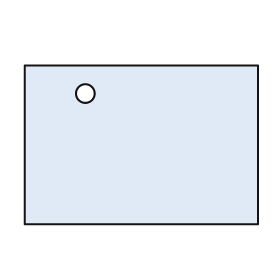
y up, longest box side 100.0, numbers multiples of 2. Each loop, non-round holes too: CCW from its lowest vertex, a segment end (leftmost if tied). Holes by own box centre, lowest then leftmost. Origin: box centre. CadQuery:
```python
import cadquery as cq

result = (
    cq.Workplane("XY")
    .moveTo(-50.0, -34.0)
    .lineTo(50.0, -34.0)
    .lineTo(50.0, 34.0)
    .lineTo(-50.0, 34.0)
    .close()
    .moveTo(-24.0, 22.0)
    .circle(4.0)
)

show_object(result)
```